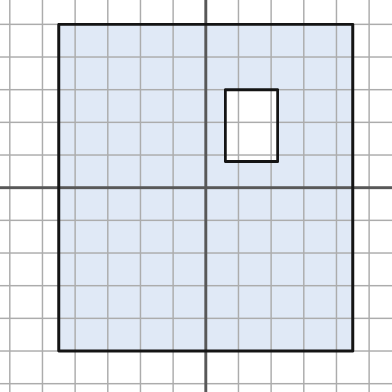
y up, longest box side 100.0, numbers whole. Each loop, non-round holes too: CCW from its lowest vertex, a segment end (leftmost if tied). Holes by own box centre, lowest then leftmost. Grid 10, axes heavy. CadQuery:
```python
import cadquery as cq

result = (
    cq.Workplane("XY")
    .moveTo(-45.0, -50.0)
    .lineTo(45.0, -50.0)
    .lineTo(45.0, 50.0)
    .lineTo(-45.0, 50.0)
    .close()
    .moveTo(6.0, 8.0)
    .lineTo(22.0, 8.0)
    .lineTo(22.0, 30.0)
    .lineTo(6.0, 30.0)
    .close()
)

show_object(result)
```